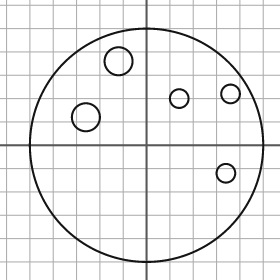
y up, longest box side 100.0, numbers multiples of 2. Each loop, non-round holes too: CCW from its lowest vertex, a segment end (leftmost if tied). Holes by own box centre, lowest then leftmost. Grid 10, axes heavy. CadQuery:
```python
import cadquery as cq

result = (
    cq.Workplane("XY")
    .moveTo(0.0, 0.0)
    .circle(50.0)
    .moveTo(34.0, -12.0)
    .circle(4.0)
    .moveTo(-26.0, 12.0)
    .circle(6.0)
    .moveTo(14.0, 20.0)
    .circle(4.0)
    .moveTo(36.0, 22.0)
    .circle(4.0)
    .moveTo(-12.0, 36.0)
    .circle(6.0)
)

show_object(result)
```